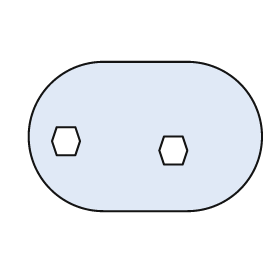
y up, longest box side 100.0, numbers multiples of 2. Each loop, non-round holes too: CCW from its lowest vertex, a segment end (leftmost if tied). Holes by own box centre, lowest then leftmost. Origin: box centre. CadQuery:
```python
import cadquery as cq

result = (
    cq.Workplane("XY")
    .moveTo(-18.0, -32.0)
    .lineTo(18.0, -32.0)
    .threePointArc((50.0, 0.0), (18.0, 32.0))
    .lineTo(-18.0, 32.0)
    .threePointArc((-50.0, 0.0), (-18.0, -32.0))
    .close()
    .moveTo(8.0, -12.0)
    .lineTo(16.0, -12.0)
    .lineTo(18.0, -6.0)
    .lineTo(16.0, 0.0)
    .lineTo(8.0, 0.0)
    .lineTo(6.0, -6.0)
    .close()
    .moveTo(-38.0, -8.0)
    .lineTo(-30.0, -8.0)
    .lineTo(-28.0, -2.0)
    .lineTo(-30.0, 4.0)
    .lineTo(-38.0, 4.0)
    .lineTo(-40.0, -2.0)
    .close()
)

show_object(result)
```